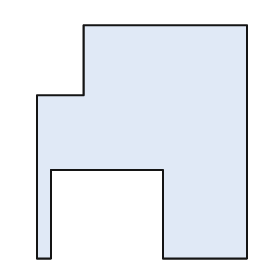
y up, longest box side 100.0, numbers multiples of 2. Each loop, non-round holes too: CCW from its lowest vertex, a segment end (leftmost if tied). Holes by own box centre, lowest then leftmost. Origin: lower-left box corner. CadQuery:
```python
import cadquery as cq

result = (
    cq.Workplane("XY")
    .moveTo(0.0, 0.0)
    .lineTo(6.0, 0.0)
    .lineTo(6.0, 38.0)
    .lineTo(54.0, 38.0)
    .lineTo(54.0, 0.0)
    .lineTo(90.0, 0.0)
    .lineTo(90.0, 100.0)
    .lineTo(20.0, 100.0)
    .lineTo(20.0, 70.0)
    .lineTo(0.0, 70.0)
    .close()
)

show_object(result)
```